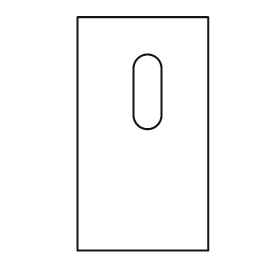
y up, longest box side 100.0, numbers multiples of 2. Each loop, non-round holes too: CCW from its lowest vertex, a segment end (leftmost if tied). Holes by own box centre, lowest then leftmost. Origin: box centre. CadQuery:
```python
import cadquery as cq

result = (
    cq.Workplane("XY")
    .moveTo(-28.0, -50.0)
    .lineTo(28.0, -50.0)
    .lineTo(28.0, 50.0)
    .lineTo(-28.0, 50.0)
    .close()
    .moveTo(-4.0, 8.0)
    .threePointArc((2.0, 2.0), (8.0, 8.0))
    .lineTo(8.0, 28.0)
    .threePointArc((2.0, 34.0), (-4.0, 28.0))
    .close()
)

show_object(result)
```